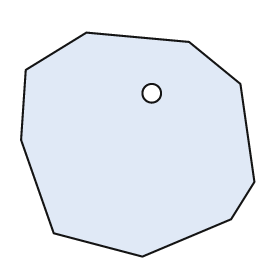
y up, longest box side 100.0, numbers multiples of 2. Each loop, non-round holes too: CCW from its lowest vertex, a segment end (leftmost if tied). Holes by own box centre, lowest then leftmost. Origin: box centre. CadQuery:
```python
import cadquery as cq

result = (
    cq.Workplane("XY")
    .moveTo(2.0, -48.0)
    .lineTo(40.0, -32.0)
    .lineTo(50.0, -16.0)
    .lineTo(44.0, 26.0)
    .lineTo(22.0, 44.0)
    .lineTo(-22.0, 48.0)
    .lineTo(-48.0, 32.0)
    .lineTo(-50.0, 2.0)
    .lineTo(-36.0, -38.0)
    .close()
    .moveTo(6.0, 22.0)
    .circle(4.0)
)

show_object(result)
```